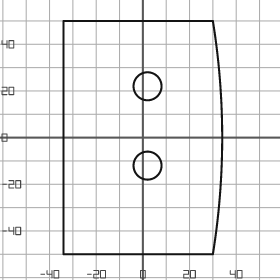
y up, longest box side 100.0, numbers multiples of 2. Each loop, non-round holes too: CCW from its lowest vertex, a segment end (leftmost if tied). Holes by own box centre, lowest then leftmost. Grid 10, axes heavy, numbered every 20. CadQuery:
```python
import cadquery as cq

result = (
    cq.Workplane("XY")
    .moveTo(-34.0, -50.0)
    .lineTo(30.0, -50.0)
    .threePointArc((34.0, 0.0), (30.0, 50.0))
    .lineTo(-34.0, 50.0)
    .close()
    .moveTo(2.0, -12.0)
    .circle(6.0)
    .moveTo(2.0, 22.0)
    .circle(6.0)
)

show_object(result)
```